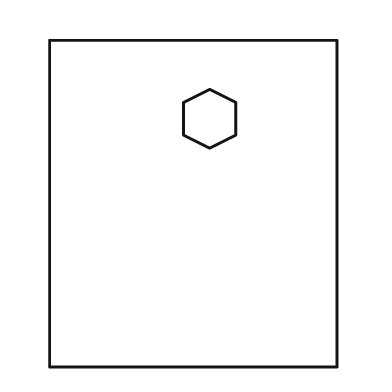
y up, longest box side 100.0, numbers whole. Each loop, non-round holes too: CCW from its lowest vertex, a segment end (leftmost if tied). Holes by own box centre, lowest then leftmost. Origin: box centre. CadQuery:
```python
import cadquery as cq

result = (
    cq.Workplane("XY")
    .moveTo(-44.0, -50.0)
    .lineTo(44.0, -50.0)
    .lineTo(44.0, 50.0)
    .lineTo(-44.0, 50.0)
    .close()
    .moveTo(5.0, 17.0)
    .lineTo(13.0, 21.0)
    .lineTo(13.0, 31.0)
    .lineTo(5.0, 35.0)
    .lineTo(-3.0, 31.0)
    .lineTo(-3.0, 21.0)
    .close()
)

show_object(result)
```